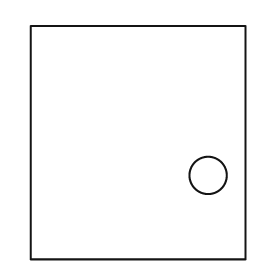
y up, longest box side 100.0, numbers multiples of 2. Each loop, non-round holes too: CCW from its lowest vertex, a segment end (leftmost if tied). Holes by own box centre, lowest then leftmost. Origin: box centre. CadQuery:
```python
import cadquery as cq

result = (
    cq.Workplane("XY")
    .moveTo(-46.0, -50.0)
    .lineTo(46.0, -50.0)
    .lineTo(46.0, 50.0)
    .lineTo(-46.0, 50.0)
    .close()
    .moveTo(30.0, -14.0)
    .circle(8.0)
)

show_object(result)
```